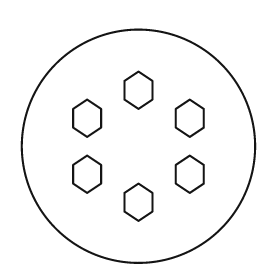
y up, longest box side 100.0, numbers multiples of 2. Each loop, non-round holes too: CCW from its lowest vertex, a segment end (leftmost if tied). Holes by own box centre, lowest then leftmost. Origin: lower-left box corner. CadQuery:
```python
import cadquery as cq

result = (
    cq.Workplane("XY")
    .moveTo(50.0, 50.0)
    .circle(50.0)
    .moveTo(50.0, 18.0)
    .lineTo(56.0, 22.0)
    .lineTo(56.0, 30.0)
    .lineTo(50.0, 34.0)
    .lineTo(44.0, 30.0)
    .lineTo(44.0, 22.0)
    .close()
    .moveTo(28.0, 30.0)
    .lineTo(34.0, 34.0)
    .lineTo(34.0, 42.0)
    .lineTo(28.0, 46.0)
    .lineTo(22.0, 42.0)
    .lineTo(22.0, 34.0)
    .close()
    .moveTo(72.0, 30.0)
    .lineTo(78.0, 34.0)
    .lineTo(78.0, 42.0)
    .lineTo(72.0, 46.0)
    .lineTo(66.0, 42.0)
    .lineTo(66.0, 34.0)
    .close()
    .moveTo(28.0, 54.0)
    .lineTo(34.0, 58.0)
    .lineTo(34.0, 66.0)
    .lineTo(28.0, 70.0)
    .lineTo(22.0, 66.0)
    .lineTo(22.0, 58.0)
    .close()
    .moveTo(72.0, 54.0)
    .lineTo(78.0, 58.0)
    .lineTo(78.0, 66.0)
    .lineTo(72.0, 70.0)
    .lineTo(66.0, 66.0)
    .lineTo(66.0, 58.0)
    .close()
    .moveTo(50.0, 66.0)
    .lineTo(56.0, 70.0)
    .lineTo(56.0, 78.0)
    .lineTo(50.0, 82.0)
    .lineTo(44.0, 78.0)
    .lineTo(44.0, 70.0)
    .close()
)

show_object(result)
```